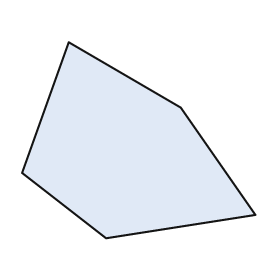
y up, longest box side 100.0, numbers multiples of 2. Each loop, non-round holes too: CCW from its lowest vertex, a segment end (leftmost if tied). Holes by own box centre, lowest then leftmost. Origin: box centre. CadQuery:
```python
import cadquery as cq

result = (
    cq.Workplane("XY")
    .moveTo(-14.0, -42.0)
    .lineTo(50.0, -32.0)
    .lineTo(18.0, 14.0)
    .lineTo(-30.0, 42.0)
    .lineTo(-50.0, -14.0)
    .close()
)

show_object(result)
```